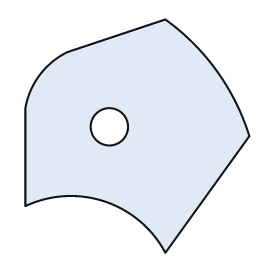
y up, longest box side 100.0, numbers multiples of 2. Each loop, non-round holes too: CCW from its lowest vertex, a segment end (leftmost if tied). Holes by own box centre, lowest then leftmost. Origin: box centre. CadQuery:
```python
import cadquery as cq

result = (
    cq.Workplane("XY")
    .moveTo(12.0, -50.0)
    .lineTo(48.0, 0.0)
    .threePointArc((34.0, 28.0), (12.0, 50.0))
    .lineTo(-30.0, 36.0)
    .threePointArc((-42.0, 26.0), (-48.0, 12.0))
    .lineTo(-48.0, -30.0)
    .threePointArc((-14.0, -28.0), (12.0, -50.0))
    .close()
    .moveTo(-12.0, 4.0)
    .circle(8.0)
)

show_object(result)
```